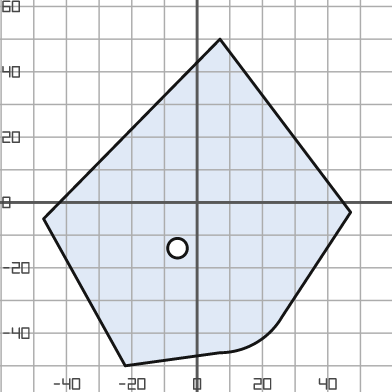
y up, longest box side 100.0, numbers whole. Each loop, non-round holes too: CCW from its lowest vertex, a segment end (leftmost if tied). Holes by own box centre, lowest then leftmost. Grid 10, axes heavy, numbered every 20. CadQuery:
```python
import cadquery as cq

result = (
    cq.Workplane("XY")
    .moveTo(-22.0, -50.0)
    .lineTo(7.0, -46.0)
    .threePointArc((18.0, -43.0), (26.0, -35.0))
    .lineTo(47.0, -3.0)
    .lineTo(7.0, 50.0)
    .lineTo(-47.0, -5.0)
    .close()
    .moveTo(-6.0, -14.0)
    .circle(3.0)
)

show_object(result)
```